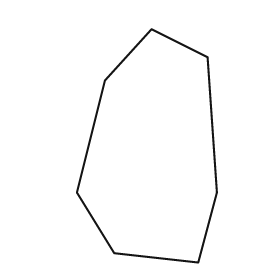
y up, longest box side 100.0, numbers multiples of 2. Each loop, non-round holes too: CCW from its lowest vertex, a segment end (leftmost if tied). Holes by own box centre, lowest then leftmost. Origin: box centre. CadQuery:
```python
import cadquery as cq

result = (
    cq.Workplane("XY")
    .moveTo(22.0, -50.0)
    .lineTo(30.0, -20.0)
    .lineTo(26.0, 38.0)
    .lineTo(2.0, 50.0)
    .lineTo(-18.0, 28.0)
    .lineTo(-30.0, -20.0)
    .lineTo(-14.0, -46.0)
    .close()
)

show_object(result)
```